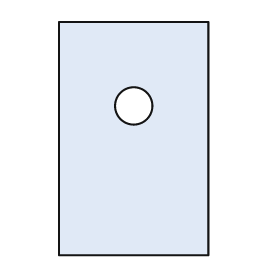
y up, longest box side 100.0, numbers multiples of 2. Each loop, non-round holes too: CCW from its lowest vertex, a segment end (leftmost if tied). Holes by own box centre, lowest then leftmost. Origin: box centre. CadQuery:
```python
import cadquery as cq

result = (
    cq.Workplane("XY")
    .moveTo(-32.0, -50.0)
    .lineTo(32.0, -50.0)
    .lineTo(32.0, 50.0)
    .lineTo(-32.0, 50.0)
    .close()
    .moveTo(0.0, 14.0)
    .circle(8.0)
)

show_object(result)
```